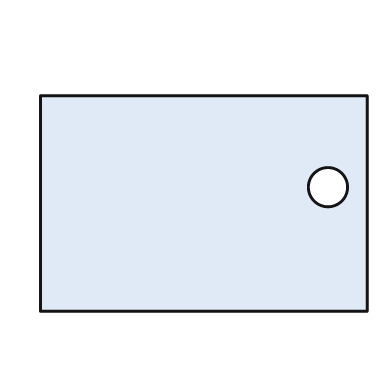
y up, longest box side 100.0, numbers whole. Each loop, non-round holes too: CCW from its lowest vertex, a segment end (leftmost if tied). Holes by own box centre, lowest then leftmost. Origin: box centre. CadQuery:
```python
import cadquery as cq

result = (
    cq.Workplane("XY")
    .moveTo(-50.0, -33.0)
    .lineTo(50.0, -33.0)
    .lineTo(50.0, 33.0)
    .lineTo(-50.0, 33.0)
    .close()
    .moveTo(38.0, 5.0)
    .circle(6.0)
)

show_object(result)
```